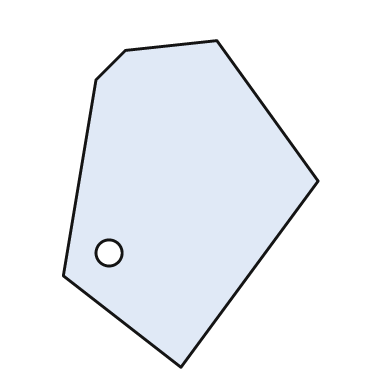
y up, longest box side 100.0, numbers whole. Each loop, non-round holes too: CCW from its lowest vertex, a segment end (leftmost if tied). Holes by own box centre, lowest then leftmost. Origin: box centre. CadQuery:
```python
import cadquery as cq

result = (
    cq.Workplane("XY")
    .moveTo(-3.0, -50.0)
    .lineTo(39.0, 7.0)
    .lineTo(8.0, 50.0)
    .lineTo(-20.0, 47.0)
    .lineTo(-29.0, 38.0)
    .lineTo(-39.0, -22.0)
    .close()
    .moveTo(-25.0, -15.0)
    .circle(4.0)
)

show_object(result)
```